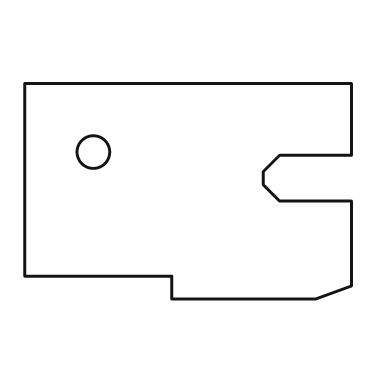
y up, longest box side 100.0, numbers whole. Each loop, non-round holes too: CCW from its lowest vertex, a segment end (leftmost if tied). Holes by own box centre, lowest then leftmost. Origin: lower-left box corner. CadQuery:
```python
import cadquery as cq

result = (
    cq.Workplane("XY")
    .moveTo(45.0, 0.0)
    .lineTo(89.0, 0.0)
    .lineTo(100.0, 4.0)
    .lineTo(100.0, 30.0)
    .lineTo(78.0, 30.0)
    .lineTo(73.0, 35.0)
    .lineTo(73.0, 39.0)
    .lineTo(78.0, 44.0)
    .lineTo(100.0, 44.0)
    .lineTo(100.0, 66.0)
    .lineTo(0.0, 66.0)
    .lineTo(0.0, 7.0)
    .lineTo(45.0, 7.0)
    .close()
    .moveTo(21.0, 45.0)
    .circle(5.0)
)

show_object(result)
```